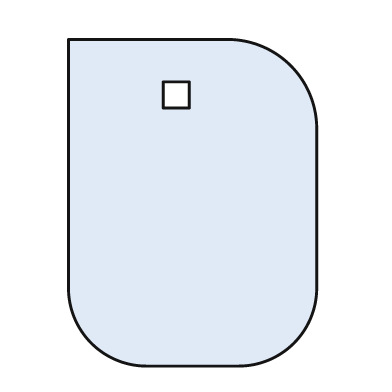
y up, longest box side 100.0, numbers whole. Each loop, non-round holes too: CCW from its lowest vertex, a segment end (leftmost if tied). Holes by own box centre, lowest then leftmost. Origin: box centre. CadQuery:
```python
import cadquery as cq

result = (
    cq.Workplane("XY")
    .moveTo(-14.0, -50.0)
    .lineTo(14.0, -50.0)
    .threePointArc((31.0, -43.0), (38.0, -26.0))
    .lineTo(38.0, 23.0)
    .threePointArc((30.0, 42.0), (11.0, 50.0))
    .lineTo(-38.0, 50.0)
    .lineTo(-38.0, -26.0)
    .threePointArc((-31.0, -43.0), (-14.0, -50.0))
    .close()
    .moveTo(-9.0, 29.0)
    .lineTo(-1.0, 29.0)
    .lineTo(-1.0, 37.0)
    .lineTo(-9.0, 37.0)
    .close()
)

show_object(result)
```